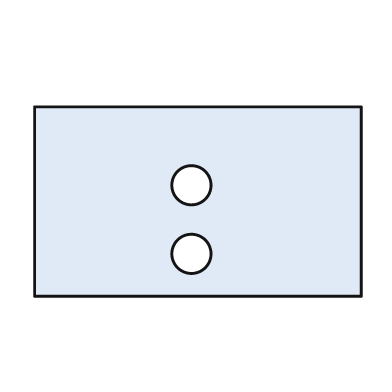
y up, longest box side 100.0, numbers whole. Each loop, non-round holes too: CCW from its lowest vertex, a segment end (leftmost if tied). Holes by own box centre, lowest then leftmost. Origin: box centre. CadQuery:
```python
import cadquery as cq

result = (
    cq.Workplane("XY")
    .moveTo(-50.0, -29.0)
    .lineTo(50.0, -29.0)
    .lineTo(50.0, 29.0)
    .lineTo(-50.0, 29.0)
    .close()
    .moveTo(-2.0, -16.0)
    .circle(6.0)
    .moveTo(-2.0, 5.0)
    .circle(6.0)
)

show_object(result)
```